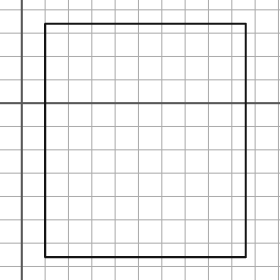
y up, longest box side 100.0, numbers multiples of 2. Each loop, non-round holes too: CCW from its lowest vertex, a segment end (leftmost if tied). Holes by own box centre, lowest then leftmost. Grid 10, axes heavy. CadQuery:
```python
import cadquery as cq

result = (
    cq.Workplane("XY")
    .moveTo(10.0, -66.0)
    .lineTo(96.0, -66.0)
    .lineTo(96.0, 34.0)
    .lineTo(10.0, 34.0)
    .close()
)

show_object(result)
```